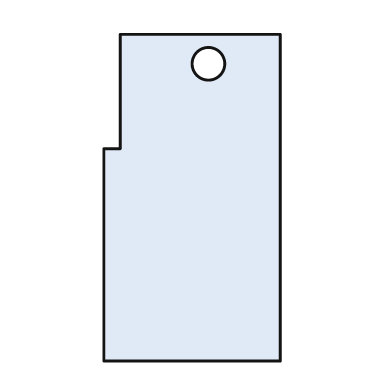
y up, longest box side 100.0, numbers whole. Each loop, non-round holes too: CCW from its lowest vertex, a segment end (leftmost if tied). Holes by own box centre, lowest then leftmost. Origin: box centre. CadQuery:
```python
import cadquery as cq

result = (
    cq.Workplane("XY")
    .moveTo(-27.0, -50.0)
    .lineTo(27.0, -50.0)
    .lineTo(27.0, 50.0)
    .lineTo(-22.0, 50.0)
    .lineTo(-22.0, 15.0)
    .lineTo(-27.0, 15.0)
    .close()
    .moveTo(5.0, 41.0)
    .circle(5.0)
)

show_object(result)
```